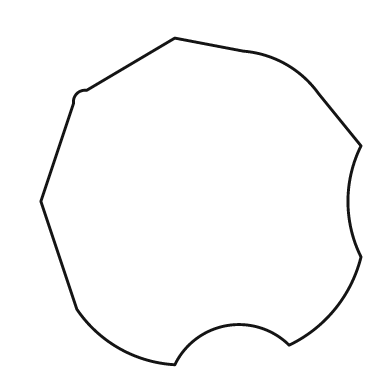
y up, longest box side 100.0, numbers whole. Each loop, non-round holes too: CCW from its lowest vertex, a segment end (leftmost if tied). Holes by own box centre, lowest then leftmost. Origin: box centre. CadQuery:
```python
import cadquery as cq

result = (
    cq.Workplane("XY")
    .moveTo(-8.0, -50.0)
    .threePointArc((8.0, -38.0), (27.0, -44.0))
    .threePointArc((41.0, -33.0), (49.0, -17.0))
    .threePointArc((45.0, 0.0), (49.0, 17.0))
    .lineTo(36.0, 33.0)
    .threePointArc((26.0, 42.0), (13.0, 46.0))
    .lineTo(-8.0, 50.0)
    .lineTo(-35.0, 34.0)
    .threePointArc((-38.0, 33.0), (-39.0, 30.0))
    .lineTo(-49.0, 0.0)
    .lineTo(-38.0, -33.0)
    .threePointArc((-25.0, -45.0), (-8.0, -50.0))
    .close()
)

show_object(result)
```